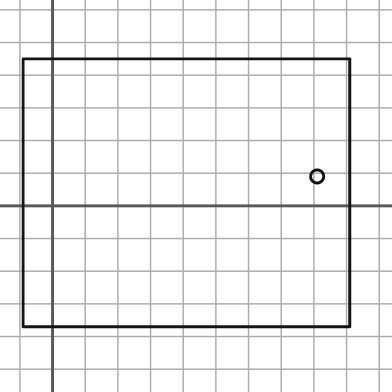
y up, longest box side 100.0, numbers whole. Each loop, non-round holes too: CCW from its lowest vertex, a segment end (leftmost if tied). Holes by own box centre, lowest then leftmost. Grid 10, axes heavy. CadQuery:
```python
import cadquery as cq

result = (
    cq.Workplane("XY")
    .moveTo(-9.0, -37.0)
    .lineTo(91.0, -37.0)
    .lineTo(91.0, 45.0)
    .lineTo(-9.0, 45.0)
    .close()
    .moveTo(81.0, 9.0)
    .circle(2.0)
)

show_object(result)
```